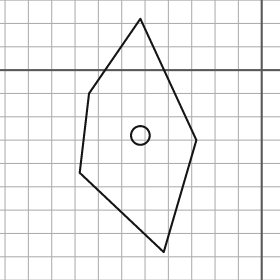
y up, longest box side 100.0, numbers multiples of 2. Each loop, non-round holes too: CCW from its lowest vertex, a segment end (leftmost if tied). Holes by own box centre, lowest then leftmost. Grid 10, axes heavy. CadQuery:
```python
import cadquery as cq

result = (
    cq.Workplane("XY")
    .moveTo(-42.0, -78.0)
    .lineTo(-28.0, -30.0)
    .lineTo(-52.0, 22.0)
    .lineTo(-74.0, -10.0)
    .lineTo(-78.0, -44.0)
    .close()
    .moveTo(-52.0, -28.0)
    .circle(4.0)
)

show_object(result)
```